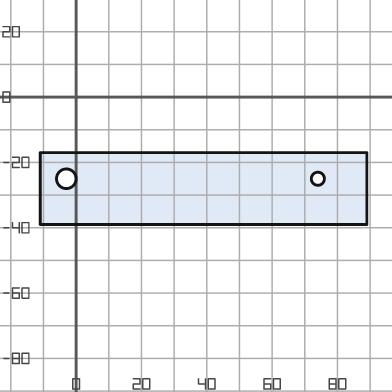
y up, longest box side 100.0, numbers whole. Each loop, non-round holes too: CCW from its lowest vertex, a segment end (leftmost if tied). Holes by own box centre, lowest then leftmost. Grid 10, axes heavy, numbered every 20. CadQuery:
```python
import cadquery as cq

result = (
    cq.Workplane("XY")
    .moveTo(-11.0, -39.0)
    .lineTo(89.0, -39.0)
    .lineTo(89.0, -17.0)
    .lineTo(-11.0, -17.0)
    .close()
    .moveTo(-3.0, -25.0)
    .circle(3.0)
    .moveTo(74.0, -25.0)
    .circle(2.0)
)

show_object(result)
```